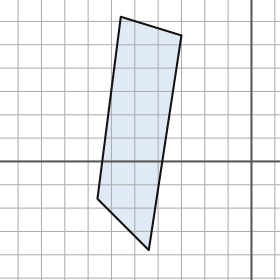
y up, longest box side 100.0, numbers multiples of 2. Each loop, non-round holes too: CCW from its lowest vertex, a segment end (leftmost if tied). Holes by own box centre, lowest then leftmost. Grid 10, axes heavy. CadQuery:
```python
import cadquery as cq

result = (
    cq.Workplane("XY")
    .moveTo(-44.0, -38.0)
    .lineTo(-30.0, 54.0)
    .lineTo(-56.0, 62.0)
    .lineTo(-66.0, -16.0)
    .close()
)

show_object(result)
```